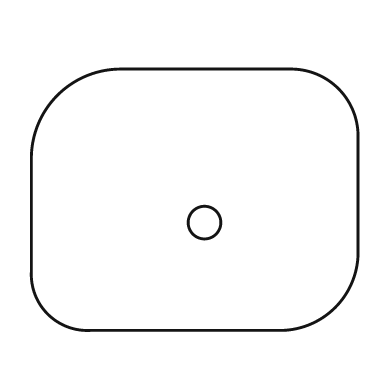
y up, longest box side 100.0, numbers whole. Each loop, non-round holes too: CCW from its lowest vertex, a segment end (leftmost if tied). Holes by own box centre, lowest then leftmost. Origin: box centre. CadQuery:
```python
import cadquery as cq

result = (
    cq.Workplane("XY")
    .moveTo(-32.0, -40.0)
    .lineTo(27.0, -40.0)
    .threePointArc((43.0, -33.0), (50.0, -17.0))
    .lineTo(50.0, 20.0)
    .threePointArc((44.0, 34.0), (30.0, 40.0))
    .lineTo(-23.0, 40.0)
    .threePointArc((-42.0, 32.0), (-50.0, 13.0))
    .lineTo(-50.0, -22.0)
    .threePointArc((-45.0, -35.0), (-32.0, -40.0))
    .close()
    .moveTo(3.0, -7.0)
    .circle(5.0)
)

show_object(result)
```